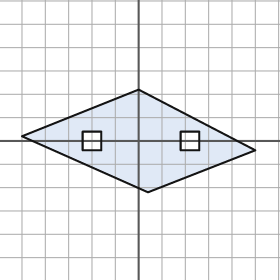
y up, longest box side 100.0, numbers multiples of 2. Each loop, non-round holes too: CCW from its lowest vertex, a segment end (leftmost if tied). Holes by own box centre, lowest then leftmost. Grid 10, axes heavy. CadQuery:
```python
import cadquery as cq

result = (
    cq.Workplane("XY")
    .moveTo(4.0, -22.0)
    .lineTo(50.0, -4.0)
    .lineTo(0.0, 22.0)
    .lineTo(-50.0, 2.0)
    .close()
    .moveTo(-24.0, -4.0)
    .lineTo(-16.0, -4.0)
    .lineTo(-16.0, 4.0)
    .lineTo(-24.0, 4.0)
    .close()
    .moveTo(18.0, -4.0)
    .lineTo(26.0, -4.0)
    .lineTo(26.0, 4.0)
    .lineTo(18.0, 4.0)
    .close()
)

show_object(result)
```